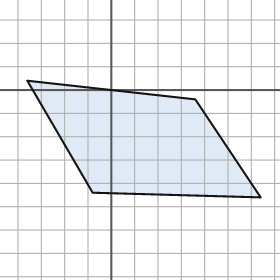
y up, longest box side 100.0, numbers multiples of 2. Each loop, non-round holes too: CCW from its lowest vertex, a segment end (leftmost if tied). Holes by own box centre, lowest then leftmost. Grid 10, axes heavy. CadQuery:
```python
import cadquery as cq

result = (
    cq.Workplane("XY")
    .moveTo(64.0, -46.0)
    .lineTo(36.0, -4.0)
    .lineTo(-36.0, 4.0)
    .lineTo(-8.0, -44.0)
    .close()
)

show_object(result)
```